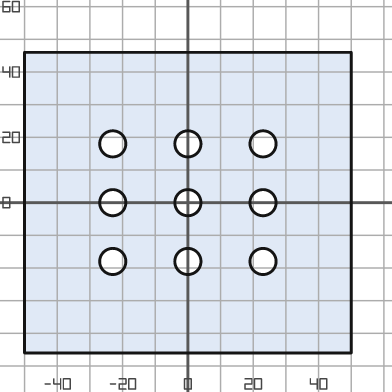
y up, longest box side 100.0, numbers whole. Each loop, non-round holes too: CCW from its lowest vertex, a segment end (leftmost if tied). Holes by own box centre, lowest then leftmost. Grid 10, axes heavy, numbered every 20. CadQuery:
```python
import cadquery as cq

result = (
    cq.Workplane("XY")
    .moveTo(-50.0, -46.0)
    .lineTo(50.0, -46.0)
    .lineTo(50.0, 46.0)
    .lineTo(-50.0, 46.0)
    .close()
    .moveTo(-23.0, -18.0)
    .circle(4.0)
    .moveTo(0.0, -18.0)
    .circle(4.0)
    .moveTo(23.0, -18.0)
    .circle(4.0)
    .moveTo(-23.0, 0.0)
    .circle(4.0)
    .moveTo(0.0, 0.0)
    .circle(4.0)
    .moveTo(23.0, 0.0)
    .circle(4.0)
    .moveTo(-23.0, 18.0)
    .circle(4.0)
    .moveTo(0.0, 18.0)
    .circle(4.0)
    .moveTo(23.0, 18.0)
    .circle(4.0)
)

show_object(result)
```